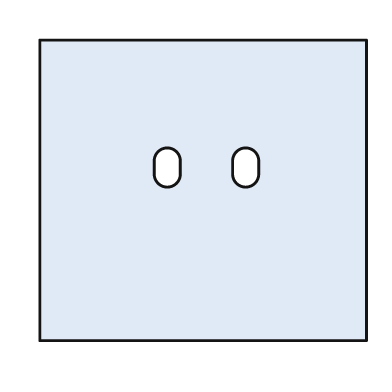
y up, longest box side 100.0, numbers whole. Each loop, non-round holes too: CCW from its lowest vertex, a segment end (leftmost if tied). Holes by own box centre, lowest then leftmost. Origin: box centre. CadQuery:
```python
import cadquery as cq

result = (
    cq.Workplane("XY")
    .moveTo(-50.0, -46.0)
    .lineTo(50.0, -46.0)
    .lineTo(50.0, 46.0)
    .lineTo(-50.0, 46.0)
    .close()
    .moveTo(-15.0, 5.0)
    .threePointArc((-11.0, 1.0), (-7.0, 5.0))
    .lineTo(-7.0, 9.0)
    .threePointArc((-11.0, 13.0), (-15.0, 9.0))
    .close()
    .moveTo(9.0, 5.0)
    .threePointArc((13.0, 1.0), (17.0, 5.0))
    .lineTo(17.0, 9.0)
    .threePointArc((13.0, 13.0), (9.0, 9.0))
    .close()
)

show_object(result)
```